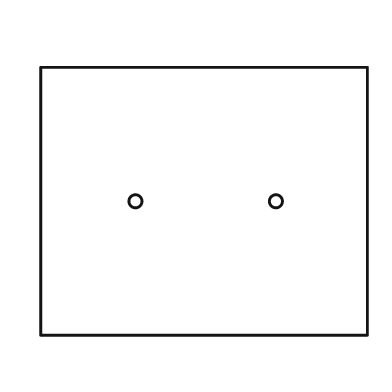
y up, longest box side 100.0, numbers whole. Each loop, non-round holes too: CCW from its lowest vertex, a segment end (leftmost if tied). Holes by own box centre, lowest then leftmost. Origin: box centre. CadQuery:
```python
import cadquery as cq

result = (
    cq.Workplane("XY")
    .moveTo(-50.0, -41.0)
    .lineTo(50.0, -41.0)
    .lineTo(50.0, 41.0)
    .lineTo(-50.0, 41.0)
    .close()
    .moveTo(-21.0, 0.0)
    .circle(2.0)
    .moveTo(22.0, 0.0)
    .circle(2.0)
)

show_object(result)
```